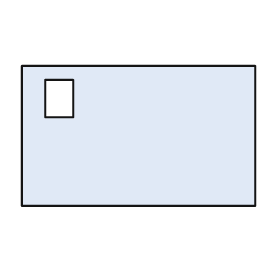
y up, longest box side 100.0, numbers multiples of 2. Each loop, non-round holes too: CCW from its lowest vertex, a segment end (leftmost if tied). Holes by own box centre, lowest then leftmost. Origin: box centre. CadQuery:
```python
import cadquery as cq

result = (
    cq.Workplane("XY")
    .moveTo(-50.0, -30.0)
    .lineTo(50.0, -30.0)
    .lineTo(50.0, 30.0)
    .lineTo(-50.0, 30.0)
    .close()
    .moveTo(-40.0, 8.0)
    .lineTo(-28.0, 8.0)
    .lineTo(-28.0, 24.0)
    .lineTo(-40.0, 24.0)
    .close()
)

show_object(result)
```